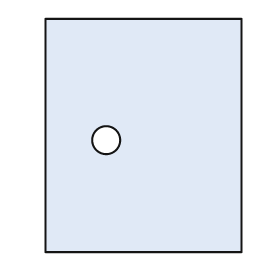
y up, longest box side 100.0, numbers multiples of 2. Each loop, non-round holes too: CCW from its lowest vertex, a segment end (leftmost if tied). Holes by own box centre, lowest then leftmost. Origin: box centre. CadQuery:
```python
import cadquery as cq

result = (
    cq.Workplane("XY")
    .moveTo(-42.0, -50.0)
    .lineTo(42.0, -50.0)
    .lineTo(42.0, 50.0)
    .lineTo(-42.0, 50.0)
    .close()
    .moveTo(-16.0, -2.0)
    .circle(6.0)
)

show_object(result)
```